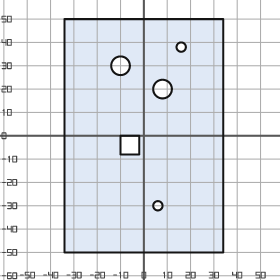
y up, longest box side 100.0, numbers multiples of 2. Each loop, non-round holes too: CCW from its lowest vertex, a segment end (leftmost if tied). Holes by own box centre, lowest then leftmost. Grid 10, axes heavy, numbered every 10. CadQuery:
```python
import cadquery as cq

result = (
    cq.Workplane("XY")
    .moveTo(-34.0, -50.0)
    .lineTo(34.0, -50.0)
    .lineTo(34.0, 50.0)
    .lineTo(-34.0, 50.0)
    .close()
    .moveTo(6.0, -30.0)
    .circle(2.0)
    .moveTo(-10.0, -8.0)
    .lineTo(-2.0, -8.0)
    .lineTo(-2.0, 0.0)
    .lineTo(-10.0, 0.0)
    .close()
    .moveTo(8.0, 20.0)
    .circle(4.0)
    .moveTo(-10.0, 30.0)
    .circle(4.0)
    .moveTo(16.0, 38.0)
    .circle(2.0)
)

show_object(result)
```